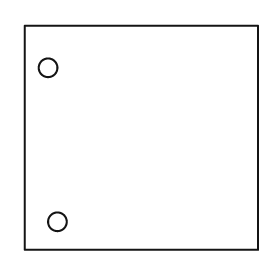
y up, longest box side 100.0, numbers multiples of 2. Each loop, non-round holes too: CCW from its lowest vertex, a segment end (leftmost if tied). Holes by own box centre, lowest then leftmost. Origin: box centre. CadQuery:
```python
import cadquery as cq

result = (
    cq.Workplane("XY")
    .moveTo(-50.0, -48.0)
    .lineTo(50.0, -48.0)
    .lineTo(50.0, 48.0)
    .lineTo(-50.0, 48.0)
    .close()
    .moveTo(-36.0, -36.0)
    .circle(4.0)
    .moveTo(-40.0, 30.0)
    .circle(4.0)
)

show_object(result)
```